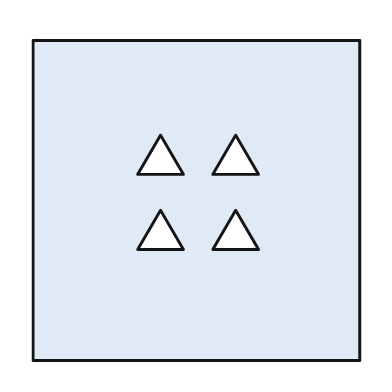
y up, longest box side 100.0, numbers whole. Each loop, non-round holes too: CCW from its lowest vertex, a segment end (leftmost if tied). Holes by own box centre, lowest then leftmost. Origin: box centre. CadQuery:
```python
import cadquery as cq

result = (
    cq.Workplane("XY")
    .moveTo(-50.0, -49.0)
    .lineTo(50.0, -49.0)
    .lineTo(50.0, 49.0)
    .lineTo(-50.0, 49.0)
    .close()
    .moveTo(-18.0, -15.0)
    .lineTo(-4.0, -15.0)
    .lineTo(-11.0, -3.0)
    .close()
    .moveTo(5.0, -15.0)
    .lineTo(19.0, -15.0)
    .lineTo(12.0, -3.0)
    .close()
    .moveTo(-18.0, 8.0)
    .lineTo(-4.0, 8.0)
    .lineTo(-11.0, 20.0)
    .close()
    .moveTo(5.0, 8.0)
    .lineTo(19.0, 8.0)
    .lineTo(12.0, 20.0)
    .close()
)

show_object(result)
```